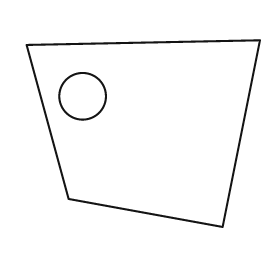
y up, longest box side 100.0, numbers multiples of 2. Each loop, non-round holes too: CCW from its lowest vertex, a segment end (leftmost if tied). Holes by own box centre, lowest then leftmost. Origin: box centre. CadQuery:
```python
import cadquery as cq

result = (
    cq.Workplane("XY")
    .moveTo(34.0, -40.0)
    .lineTo(50.0, 40.0)
    .lineTo(-50.0, 38.0)
    .lineTo(-32.0, -28.0)
    .close()
    .moveTo(-26.0, 16.0)
    .circle(10.0)
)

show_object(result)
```